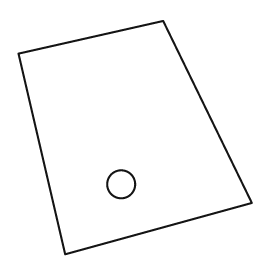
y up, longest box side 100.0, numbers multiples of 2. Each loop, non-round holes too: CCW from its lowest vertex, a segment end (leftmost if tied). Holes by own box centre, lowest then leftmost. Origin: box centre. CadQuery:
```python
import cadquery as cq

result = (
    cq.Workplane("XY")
    .moveTo(-30.0, -50.0)
    .lineTo(50.0, -28.0)
    .lineTo(12.0, 50.0)
    .lineTo(-50.0, 36.0)
    .close()
    .moveTo(-6.0, -20.0)
    .circle(6.0)
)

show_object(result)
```